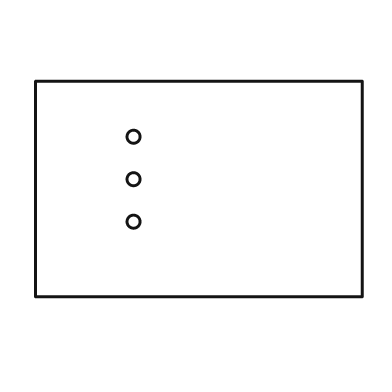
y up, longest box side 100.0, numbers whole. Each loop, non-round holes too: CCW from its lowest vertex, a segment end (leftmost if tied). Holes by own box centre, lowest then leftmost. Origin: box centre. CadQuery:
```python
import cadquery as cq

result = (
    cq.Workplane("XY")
    .moveTo(-50.0, -33.0)
    .lineTo(50.0, -33.0)
    .lineTo(50.0, 33.0)
    .lineTo(-50.0, 33.0)
    .close()
    .moveTo(-20.0, -10.0)
    .circle(2.0)
    .moveTo(-20.0, 3.0)
    .circle(2.0)
    .moveTo(-20.0, 16.0)
    .circle(2.0)
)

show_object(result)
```